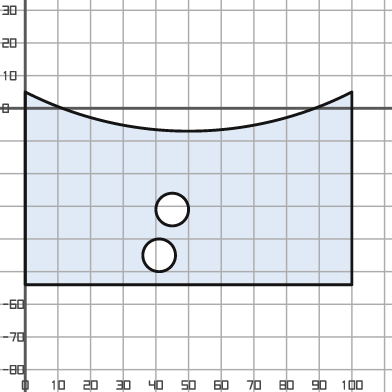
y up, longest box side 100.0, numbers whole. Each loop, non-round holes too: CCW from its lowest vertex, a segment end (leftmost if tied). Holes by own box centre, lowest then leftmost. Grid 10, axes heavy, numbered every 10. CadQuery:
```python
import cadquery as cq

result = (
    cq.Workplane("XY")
    .moveTo(0.0, -54.0)
    .lineTo(100.0, -54.0)
    .lineTo(100.0, 5.0)
    .threePointArc((50.0, -7.0), (0.0, 5.0))
    .close()
    .moveTo(41.0, -45.0)
    .circle(5.0)
    .moveTo(45.0, -31.0)
    .circle(5.0)
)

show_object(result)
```